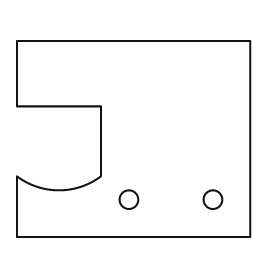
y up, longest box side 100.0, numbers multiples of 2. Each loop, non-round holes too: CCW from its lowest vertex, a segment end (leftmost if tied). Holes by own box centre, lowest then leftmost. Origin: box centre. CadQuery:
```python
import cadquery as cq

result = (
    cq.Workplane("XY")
    .moveTo(-50.0, -42.0)
    .lineTo(50.0, -42.0)
    .lineTo(50.0, 42.0)
    .lineTo(-50.0, 42.0)
    .lineTo(-50.0, 14.0)
    .lineTo(-14.0, 14.0)
    .lineTo(-14.0, -16.0)
    .threePointArc((-32.0, -22.0), (-50.0, -16.0))
    .close()
    .moveTo(-2.0, -26.0)
    .circle(4.0)
    .moveTo(34.0, -26.0)
    .circle(4.0)
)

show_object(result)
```